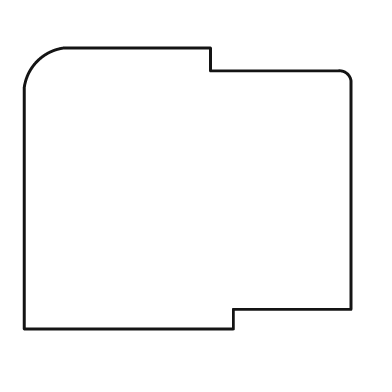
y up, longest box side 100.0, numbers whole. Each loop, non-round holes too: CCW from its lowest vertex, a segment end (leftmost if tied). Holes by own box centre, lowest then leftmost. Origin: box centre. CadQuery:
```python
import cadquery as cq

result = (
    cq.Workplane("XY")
    .moveTo(-50.0, -43.0)
    .lineTo(14.0, -43.0)
    .lineTo(14.0, -37.0)
    .lineTo(50.0, -37.0)
    .lineTo(50.0, 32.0)
    .threePointArc((49.0, 35.0), (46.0, 36.0))
    .lineTo(7.0, 36.0)
    .lineTo(7.0, 43.0)
    .lineTo(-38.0, 43.0)
    .threePointArc((-46.0, 39.0), (-50.0, 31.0))
    .close()
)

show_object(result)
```